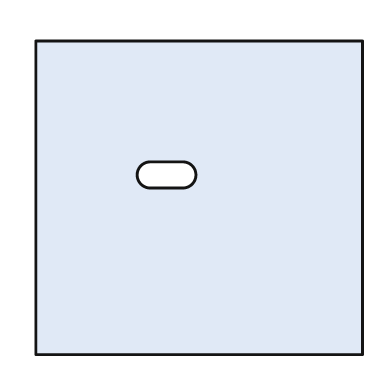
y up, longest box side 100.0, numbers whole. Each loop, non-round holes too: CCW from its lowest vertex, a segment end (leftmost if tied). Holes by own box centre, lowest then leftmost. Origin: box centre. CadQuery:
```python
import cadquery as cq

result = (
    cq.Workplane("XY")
    .moveTo(-50.0, -48.0)
    .lineTo(50.0, -48.0)
    .lineTo(50.0, 48.0)
    .lineTo(-50.0, 48.0)
    .close()
    .moveTo(-15.0, 3.0)
    .lineTo(-5.0, 3.0)
    .threePointArc((-1.0, 7.0), (-5.0, 11.0))
    .lineTo(-15.0, 11.0)
    .threePointArc((-19.0, 7.0), (-15.0, 3.0))
    .close()
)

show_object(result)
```